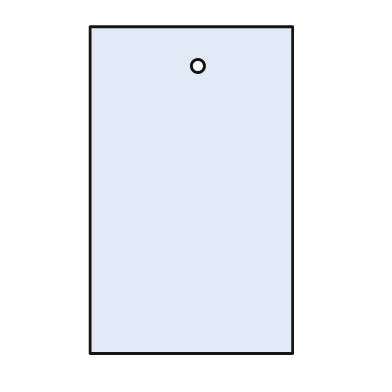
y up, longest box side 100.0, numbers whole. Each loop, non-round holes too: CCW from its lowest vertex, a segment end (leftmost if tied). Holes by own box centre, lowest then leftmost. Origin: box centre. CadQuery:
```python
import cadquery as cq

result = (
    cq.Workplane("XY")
    .moveTo(-31.0, -50.0)
    .lineTo(31.0, -50.0)
    .lineTo(31.0, 50.0)
    .lineTo(-31.0, 50.0)
    .close()
    .moveTo(2.0, 38.0)
    .circle(2.0)
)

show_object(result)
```